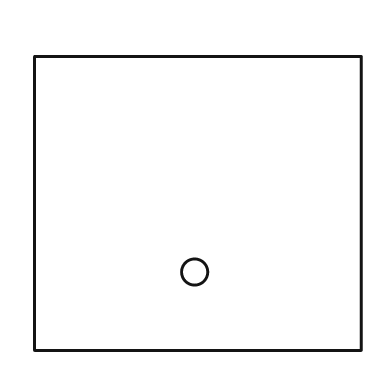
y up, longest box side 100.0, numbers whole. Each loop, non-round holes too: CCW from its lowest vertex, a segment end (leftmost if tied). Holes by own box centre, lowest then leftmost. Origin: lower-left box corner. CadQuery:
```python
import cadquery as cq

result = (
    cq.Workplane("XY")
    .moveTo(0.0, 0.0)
    .lineTo(100.0, 0.0)
    .lineTo(100.0, 90.0)
    .lineTo(0.0, 90.0)
    .close()
    .moveTo(49.0, 24.0)
    .circle(4.0)
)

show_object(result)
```